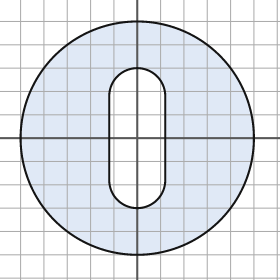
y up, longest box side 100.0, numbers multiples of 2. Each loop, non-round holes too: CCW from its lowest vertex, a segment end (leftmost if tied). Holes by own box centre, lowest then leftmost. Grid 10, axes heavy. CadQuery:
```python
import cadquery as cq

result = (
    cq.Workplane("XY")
    .moveTo(0.0, 0.0)
    .circle(50.0)
    .moveTo(-12.0, -18.0)
    .threePointArc((0.0, -30.0), (12.0, -18.0))
    .lineTo(12.0, 18.0)
    .threePointArc((0.0, 30.0), (-12.0, 18.0))
    .close()
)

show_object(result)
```